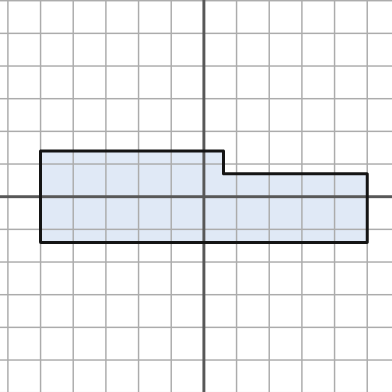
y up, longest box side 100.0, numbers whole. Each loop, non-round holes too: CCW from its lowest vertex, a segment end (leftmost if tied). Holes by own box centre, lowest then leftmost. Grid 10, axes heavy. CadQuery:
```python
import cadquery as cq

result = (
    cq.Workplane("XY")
    .moveTo(-50.0, -14.0)
    .lineTo(50.0, -14.0)
    .lineTo(50.0, 7.0)
    .lineTo(6.0, 7.0)
    .lineTo(6.0, 14.0)
    .lineTo(-50.0, 14.0)
    .close()
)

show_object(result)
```